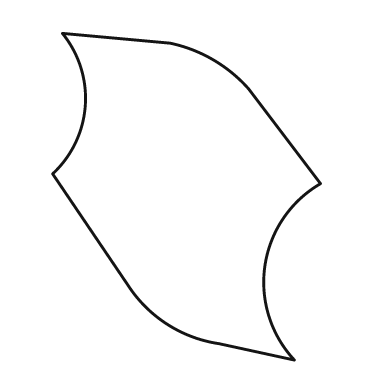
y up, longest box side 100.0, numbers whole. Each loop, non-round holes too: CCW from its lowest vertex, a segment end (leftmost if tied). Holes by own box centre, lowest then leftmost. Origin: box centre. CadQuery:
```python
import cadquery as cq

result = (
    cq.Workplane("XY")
    .moveTo(33.0, -50.0)
    .threePointArc((24.0, -21.0), (41.0, 4.0))
    .lineTo(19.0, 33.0)
    .threePointArc((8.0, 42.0), (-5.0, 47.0))
    .lineTo(-38.0, 50.0)
    .threePointArc((-31.0, 28.0), (-41.0, 7.0))
    .lineTo(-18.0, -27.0)
    .threePointArc((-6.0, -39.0), (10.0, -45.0))
    .close()
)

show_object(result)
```